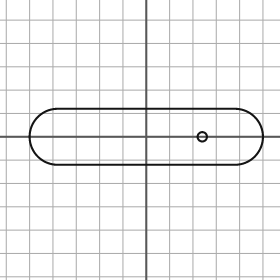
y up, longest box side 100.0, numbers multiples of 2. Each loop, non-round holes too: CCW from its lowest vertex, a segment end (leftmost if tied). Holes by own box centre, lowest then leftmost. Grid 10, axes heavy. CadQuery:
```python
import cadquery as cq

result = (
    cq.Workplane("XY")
    .moveTo(-38.0, -12.0)
    .lineTo(38.0, -12.0)
    .threePointArc((50.0, 0.0), (38.0, 12.0))
    .lineTo(-38.0, 12.0)
    .threePointArc((-50.0, 0.0), (-38.0, -12.0))
    .close()
    .moveTo(24.0, 0.0)
    .circle(2.0)
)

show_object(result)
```